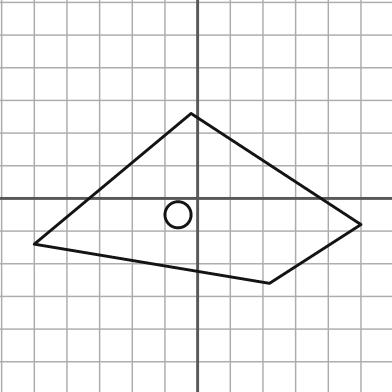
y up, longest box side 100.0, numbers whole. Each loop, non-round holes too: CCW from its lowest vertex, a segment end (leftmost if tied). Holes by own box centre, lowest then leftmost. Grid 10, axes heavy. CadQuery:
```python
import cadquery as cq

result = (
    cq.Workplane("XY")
    .moveTo(22.0, -26.0)
    .lineTo(50.0, -8.0)
    .lineTo(-2.0, 26.0)
    .lineTo(-50.0, -14.0)
    .close()
    .moveTo(-6.0, -5.0)
    .circle(4.0)
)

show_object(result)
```